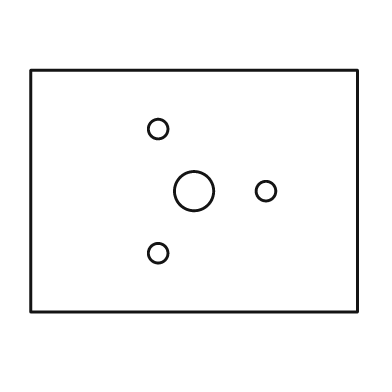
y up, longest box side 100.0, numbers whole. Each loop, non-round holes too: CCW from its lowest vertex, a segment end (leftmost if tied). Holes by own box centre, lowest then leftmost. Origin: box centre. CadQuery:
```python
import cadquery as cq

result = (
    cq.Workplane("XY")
    .moveTo(-50.0, -37.0)
    .lineTo(50.0, -37.0)
    .lineTo(50.0, 37.0)
    .lineTo(-50.0, 37.0)
    .close()
    .moveTo(-11.0, -19.0)
    .circle(3.0)
    .moveTo(0.0, 0.0)
    .circle(6.0)
    .moveTo(22.0, 0.0)
    .circle(3.0)
    .moveTo(-11.0, 19.0)
    .circle(3.0)
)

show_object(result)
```